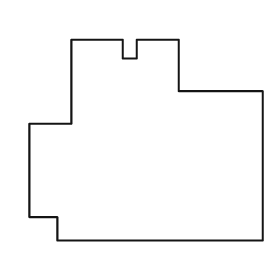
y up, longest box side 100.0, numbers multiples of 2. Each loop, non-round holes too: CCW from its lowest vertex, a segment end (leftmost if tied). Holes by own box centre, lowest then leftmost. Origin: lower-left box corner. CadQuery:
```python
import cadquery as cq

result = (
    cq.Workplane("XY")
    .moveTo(12.0, 0.0)
    .lineTo(100.0, 0.0)
    .lineTo(100.0, 64.0)
    .lineTo(64.0, 64.0)
    .lineTo(64.0, 86.0)
    .lineTo(46.0, 86.0)
    .lineTo(46.0, 78.0)
    .lineTo(40.0, 78.0)
    .lineTo(40.0, 86.0)
    .lineTo(18.0, 86.0)
    .lineTo(18.0, 50.0)
    .lineTo(0.0, 50.0)
    .lineTo(0.0, 10.0)
    .lineTo(12.0, 10.0)
    .close()
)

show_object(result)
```